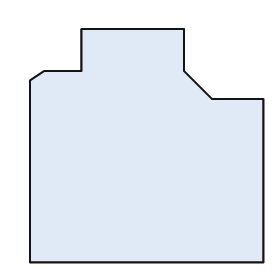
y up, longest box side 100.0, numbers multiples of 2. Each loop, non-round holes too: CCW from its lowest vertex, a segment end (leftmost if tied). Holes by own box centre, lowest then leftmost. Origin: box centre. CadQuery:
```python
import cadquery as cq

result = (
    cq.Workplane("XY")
    .moveTo(-50.0, -50.0)
    .lineTo(50.0, -50.0)
    .lineTo(50.0, 20.0)
    .lineTo(28.0, 20.0)
    .lineTo(16.0, 32.0)
    .lineTo(16.0, 50.0)
    .lineTo(-28.0, 50.0)
    .lineTo(-28.0, 32.0)
    .lineTo(-44.0, 32.0)
    .lineTo(-50.0, 28.0)
    .close()
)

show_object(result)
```